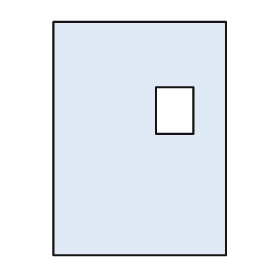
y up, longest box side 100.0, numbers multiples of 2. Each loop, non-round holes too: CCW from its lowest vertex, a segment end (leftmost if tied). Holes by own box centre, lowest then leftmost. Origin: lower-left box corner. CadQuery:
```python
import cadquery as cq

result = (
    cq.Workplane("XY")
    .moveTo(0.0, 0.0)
    .lineTo(74.0, 0.0)
    .lineTo(74.0, 100.0)
    .lineTo(0.0, 100.0)
    .close()
    .moveTo(44.0, 52.0)
    .lineTo(60.0, 52.0)
    .lineTo(60.0, 72.0)
    .lineTo(44.0, 72.0)
    .close()
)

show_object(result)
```